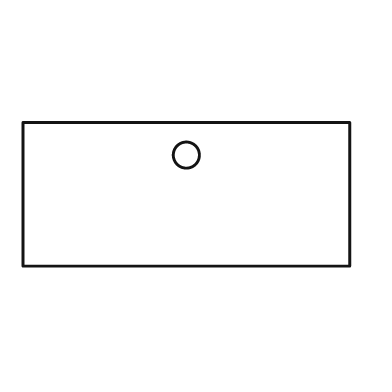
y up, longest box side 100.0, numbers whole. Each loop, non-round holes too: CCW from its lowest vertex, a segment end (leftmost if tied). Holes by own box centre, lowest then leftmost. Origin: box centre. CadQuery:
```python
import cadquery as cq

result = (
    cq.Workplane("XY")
    .moveTo(-50.0, -22.0)
    .lineTo(50.0, -22.0)
    .lineTo(50.0, 22.0)
    .lineTo(-50.0, 22.0)
    .close()
    .moveTo(0.0, 12.0)
    .circle(4.0)
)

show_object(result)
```